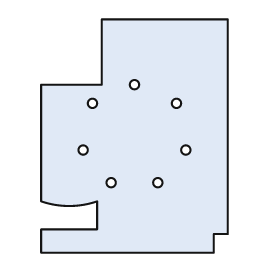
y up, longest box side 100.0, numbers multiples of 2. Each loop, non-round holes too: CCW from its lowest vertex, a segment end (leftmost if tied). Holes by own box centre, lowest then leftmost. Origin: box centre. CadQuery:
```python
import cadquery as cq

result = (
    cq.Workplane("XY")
    .moveTo(-40.0, -50.0)
    .lineTo(34.0, -50.0)
    .lineTo(34.0, -42.0)
    .lineTo(40.0, -42.0)
    .lineTo(40.0, 50.0)
    .lineTo(-14.0, 50.0)
    .lineTo(-14.0, 22.0)
    .lineTo(-40.0, 22.0)
    .lineTo(-40.0, -28.0)
    .threePointArc((-28.0, -30.0), (-16.0, -28.0))
    .lineTo(-16.0, -40.0)
    .lineTo(-40.0, -40.0)
    .close()
    .moveTo(-10.0, -20.0)
    .circle(2.0)
    .moveTo(10.0, -20.0)
    .circle(2.0)
    .moveTo(-22.0, -6.0)
    .circle(2.0)
    .moveTo(22.0, -6.0)
    .circle(2.0)
    .moveTo(-18.0, 14.0)
    .circle(2.0)
    .moveTo(18.0, 14.0)
    .circle(2.0)
    .moveTo(0.0, 22.0)
    .circle(2.0)
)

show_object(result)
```